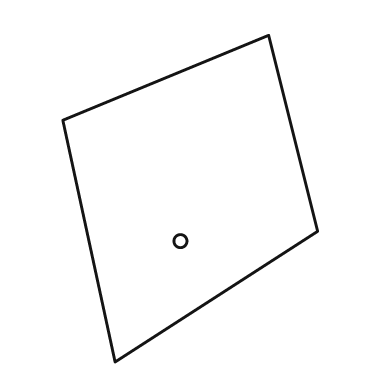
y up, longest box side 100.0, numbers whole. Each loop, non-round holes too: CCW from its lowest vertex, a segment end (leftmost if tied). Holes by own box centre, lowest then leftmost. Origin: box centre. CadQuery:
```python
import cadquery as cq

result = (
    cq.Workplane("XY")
    .moveTo(-23.0, -50.0)
    .lineTo(39.0, -10.0)
    .lineTo(24.0, 50.0)
    .lineTo(-39.0, 24.0)
    .close()
    .moveTo(-3.0, -13.0)
    .circle(2.0)
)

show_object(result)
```